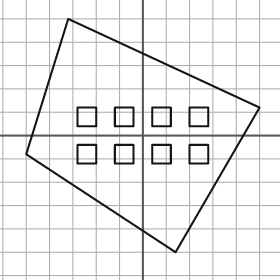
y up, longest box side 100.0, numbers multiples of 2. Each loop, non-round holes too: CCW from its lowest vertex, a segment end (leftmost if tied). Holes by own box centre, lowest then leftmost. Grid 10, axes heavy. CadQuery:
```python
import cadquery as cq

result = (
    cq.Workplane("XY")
    .moveTo(14.0, -50.0)
    .lineTo(50.0, 12.0)
    .lineTo(-32.0, 50.0)
    .lineTo(-50.0, -8.0)
    .close()
    .moveTo(-28.0, -12.0)
    .lineTo(-20.0, -12.0)
    .lineTo(-20.0, -4.0)
    .lineTo(-28.0, -4.0)
    .close()
    .moveTo(-12.0, -12.0)
    .lineTo(-4.0, -12.0)
    .lineTo(-4.0, -4.0)
    .lineTo(-12.0, -4.0)
    .close()
    .moveTo(4.0, -12.0)
    .lineTo(12.0, -12.0)
    .lineTo(12.0, -4.0)
    .lineTo(4.0, -4.0)
    .close()
    .moveTo(20.0, -12.0)
    .lineTo(28.0, -12.0)
    .lineTo(28.0, -4.0)
    .lineTo(20.0, -4.0)
    .close()
    .moveTo(-28.0, 4.0)
    .lineTo(-20.0, 4.0)
    .lineTo(-20.0, 12.0)
    .lineTo(-28.0, 12.0)
    .close()
    .moveTo(-12.0, 4.0)
    .lineTo(-4.0, 4.0)
    .lineTo(-4.0, 12.0)
    .lineTo(-12.0, 12.0)
    .close()
    .moveTo(4.0, 4.0)
    .lineTo(12.0, 4.0)
    .lineTo(12.0, 12.0)
    .lineTo(4.0, 12.0)
    .close()
    .moveTo(20.0, 4.0)
    .lineTo(28.0, 4.0)
    .lineTo(28.0, 12.0)
    .lineTo(20.0, 12.0)
    .close()
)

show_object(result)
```